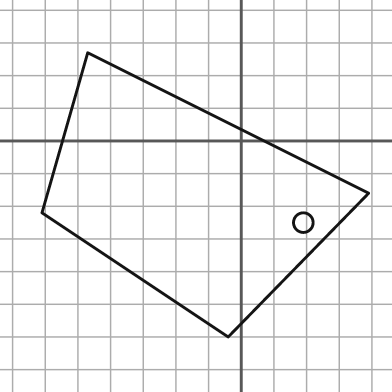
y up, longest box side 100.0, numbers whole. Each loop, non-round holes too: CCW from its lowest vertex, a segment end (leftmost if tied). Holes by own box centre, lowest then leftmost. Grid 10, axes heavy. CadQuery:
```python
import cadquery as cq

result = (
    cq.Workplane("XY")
    .moveTo(-4.0, -60.0)
    .lineTo(39.0, -16.0)
    .lineTo(-47.0, 27.0)
    .lineTo(-61.0, -22.0)
    .close()
    .moveTo(19.0, -25.0)
    .circle(3.0)
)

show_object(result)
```